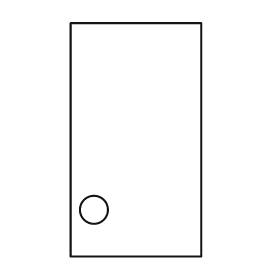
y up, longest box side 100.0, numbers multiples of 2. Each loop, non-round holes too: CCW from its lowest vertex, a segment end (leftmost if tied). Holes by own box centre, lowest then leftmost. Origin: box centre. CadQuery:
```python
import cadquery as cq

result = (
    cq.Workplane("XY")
    .moveTo(-28.0, -50.0)
    .lineTo(28.0, -50.0)
    .lineTo(28.0, 50.0)
    .lineTo(-28.0, 50.0)
    .close()
    .moveTo(-18.0, -30.0)
    .circle(6.0)
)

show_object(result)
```